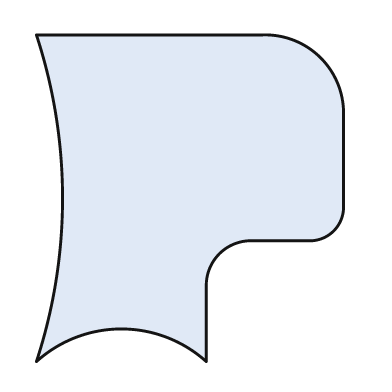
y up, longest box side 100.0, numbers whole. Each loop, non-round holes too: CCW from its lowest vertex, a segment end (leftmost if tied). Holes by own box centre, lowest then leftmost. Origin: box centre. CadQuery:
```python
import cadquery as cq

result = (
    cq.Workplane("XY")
    .moveTo(-47.0, -50.0)
    .threePointArc((-21.0, -40.0), (5.0, -50.0))
    .lineTo(5.0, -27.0)
    .threePointArc((9.0, -17.0), (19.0, -13.0))
    .lineTo(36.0, -13.0)
    .threePointArc((44.0, -10.0), (47.0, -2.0))
    .lineTo(47.0, 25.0)
    .threePointArc((40.0, 43.0), (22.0, 50.0))
    .lineTo(-47.0, 50.0)
    .threePointArc((-39.0, 0.0), (-47.0, -50.0))
    .close()
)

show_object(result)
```